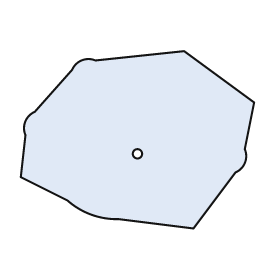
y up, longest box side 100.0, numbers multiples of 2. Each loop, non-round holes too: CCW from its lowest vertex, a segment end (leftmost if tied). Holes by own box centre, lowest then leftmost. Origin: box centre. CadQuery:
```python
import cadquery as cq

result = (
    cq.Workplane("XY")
    .moveTo(24.0, -38.0)
    .lineTo(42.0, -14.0)
    .threePointArc((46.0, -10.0), (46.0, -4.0))
    .lineTo(50.0, 16.0)
    .lineTo(20.0, 38.0)
    .lineTo(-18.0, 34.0)
    .threePointArc((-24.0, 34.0), (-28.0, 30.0))
    .lineTo(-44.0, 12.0)
    .threePointArc((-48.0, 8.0), (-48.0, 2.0))
    .lineTo(-50.0, -16.0)
    .lineTo(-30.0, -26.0)
    .threePointArc((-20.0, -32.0), (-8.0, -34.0))
    .close()
    .moveTo(0.0, -6.0)
    .circle(2.0)
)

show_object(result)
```